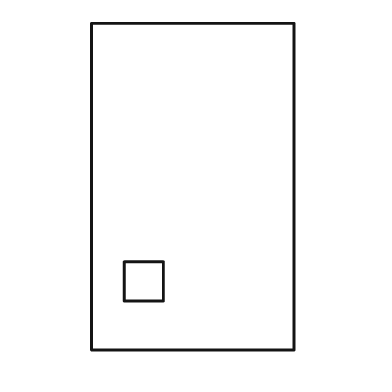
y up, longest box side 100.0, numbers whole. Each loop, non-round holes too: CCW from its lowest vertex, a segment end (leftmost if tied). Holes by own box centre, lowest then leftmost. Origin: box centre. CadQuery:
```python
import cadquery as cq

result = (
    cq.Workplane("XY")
    .moveTo(-31.0, -50.0)
    .lineTo(31.0, -50.0)
    .lineTo(31.0, 50.0)
    .lineTo(-31.0, 50.0)
    .close()
    .moveTo(-21.0, -35.0)
    .lineTo(-9.0, -35.0)
    .lineTo(-9.0, -23.0)
    .lineTo(-21.0, -23.0)
    .close()
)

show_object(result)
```